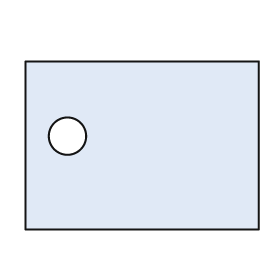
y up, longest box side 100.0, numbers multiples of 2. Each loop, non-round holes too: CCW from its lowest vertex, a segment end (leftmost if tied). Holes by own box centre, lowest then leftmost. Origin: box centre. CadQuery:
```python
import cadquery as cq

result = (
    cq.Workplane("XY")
    .moveTo(-50.0, -36.0)
    .lineTo(50.0, -36.0)
    .lineTo(50.0, 36.0)
    .lineTo(-50.0, 36.0)
    .close()
    .moveTo(-32.0, 4.0)
    .circle(8.0)
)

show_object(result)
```